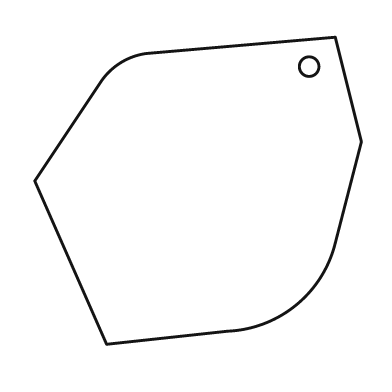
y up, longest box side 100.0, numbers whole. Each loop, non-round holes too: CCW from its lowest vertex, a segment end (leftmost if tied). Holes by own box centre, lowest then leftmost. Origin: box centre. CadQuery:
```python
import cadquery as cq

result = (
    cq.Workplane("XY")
    .moveTo(-28.0, -47.0)
    .lineTo(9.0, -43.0)
    .threePointArc((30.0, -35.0), (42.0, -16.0))
    .lineTo(50.0, 15.0)
    .lineTo(42.0, 47.0)
    .lineTo(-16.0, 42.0)
    .threePointArc((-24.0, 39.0), (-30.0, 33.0))
    .lineTo(-50.0, 3.0)
    .close()
    .moveTo(34.0, 38.0)
    .circle(3.0)
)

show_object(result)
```